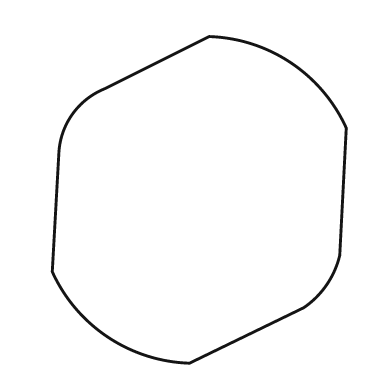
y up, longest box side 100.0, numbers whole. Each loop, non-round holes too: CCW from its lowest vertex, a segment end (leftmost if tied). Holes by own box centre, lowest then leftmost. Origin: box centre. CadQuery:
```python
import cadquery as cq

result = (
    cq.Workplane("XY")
    .moveTo(-3.0, -50.0)
    .lineTo(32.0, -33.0)
    .threePointArc((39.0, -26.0), (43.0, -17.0))
    .lineTo(45.0, 22.0)
    .threePointArc((28.0, 42.0), (3.0, 50.0))
    .lineTo(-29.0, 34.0)
    .threePointArc((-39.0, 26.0), (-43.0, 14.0))
    .lineTo(-45.0, -22.0)
    .threePointArc((-28.0, -42.0), (-3.0, -50.0))
    .close()
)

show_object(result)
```